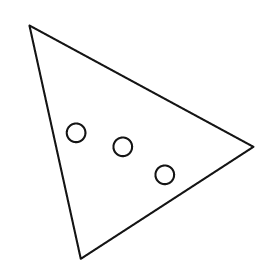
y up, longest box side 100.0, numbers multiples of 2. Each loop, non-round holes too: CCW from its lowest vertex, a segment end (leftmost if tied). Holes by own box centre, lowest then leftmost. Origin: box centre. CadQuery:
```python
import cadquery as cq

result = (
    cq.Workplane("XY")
    .moveTo(-26.0, -50.0)
    .lineTo(48.0, -2.0)
    .lineTo(-48.0, 50.0)
    .close()
    .moveTo(10.0, -14.0)
    .circle(4.0)
    .moveTo(-8.0, -2.0)
    .circle(4.0)
    .moveTo(-28.0, 4.0)
    .circle(4.0)
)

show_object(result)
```